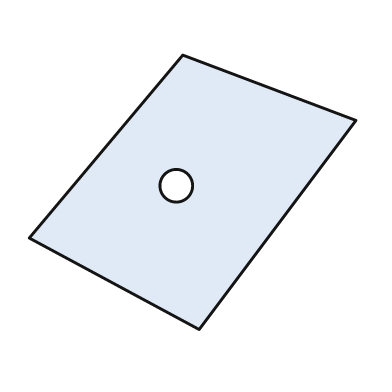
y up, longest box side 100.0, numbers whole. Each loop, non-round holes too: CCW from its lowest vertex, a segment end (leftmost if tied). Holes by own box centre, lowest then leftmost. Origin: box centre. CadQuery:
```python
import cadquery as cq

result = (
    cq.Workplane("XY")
    .moveTo(2.0, -42.0)
    .lineTo(50.0, 22.0)
    .lineTo(-3.0, 42.0)
    .lineTo(-50.0, -14.0)
    .close()
    .moveTo(-5.0, 2.0)
    .circle(5.0)
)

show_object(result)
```